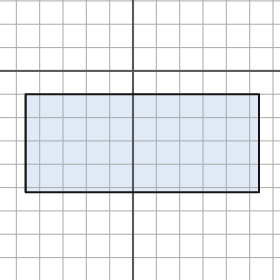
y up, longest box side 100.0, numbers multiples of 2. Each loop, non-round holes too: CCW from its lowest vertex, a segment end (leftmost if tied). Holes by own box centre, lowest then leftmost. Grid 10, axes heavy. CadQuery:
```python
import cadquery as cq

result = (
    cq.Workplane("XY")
    .moveTo(-46.0, -52.0)
    .lineTo(54.0, -52.0)
    .lineTo(54.0, -10.0)
    .lineTo(-46.0, -10.0)
    .close()
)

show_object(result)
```